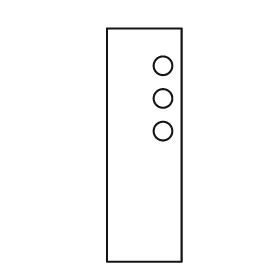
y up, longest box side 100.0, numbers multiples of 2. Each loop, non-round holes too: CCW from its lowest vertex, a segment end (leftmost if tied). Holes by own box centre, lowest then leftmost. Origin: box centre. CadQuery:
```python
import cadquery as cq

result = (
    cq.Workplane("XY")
    .moveTo(-16.0, -50.0)
    .lineTo(16.0, -50.0)
    .lineTo(16.0, 50.0)
    .lineTo(-16.0, 50.0)
    .close()
    .moveTo(8.0, 6.0)
    .circle(4.0)
    .moveTo(8.0, 20.0)
    .circle(4.0)
    .moveTo(8.0, 34.0)
    .circle(4.0)
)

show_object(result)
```